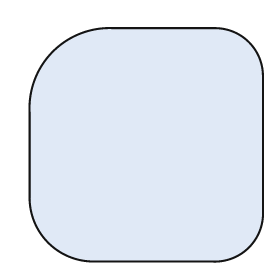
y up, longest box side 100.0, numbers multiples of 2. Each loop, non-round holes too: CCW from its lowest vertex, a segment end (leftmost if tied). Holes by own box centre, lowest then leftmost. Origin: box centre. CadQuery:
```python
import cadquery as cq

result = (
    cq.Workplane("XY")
    .moveTo(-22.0, -50.0)
    .lineTo(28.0, -50.0)
    .threePointArc((44.0, -44.0), (50.0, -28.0))
    .lineTo(50.0, 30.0)
    .threePointArc((44.0, 44.0), (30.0, 50.0))
    .lineTo(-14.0, 50.0)
    .threePointArc((-40.0, 40.0), (-50.0, 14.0))
    .lineTo(-50.0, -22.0)
    .threePointArc((-42.0, -42.0), (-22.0, -50.0))
    .close()
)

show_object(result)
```